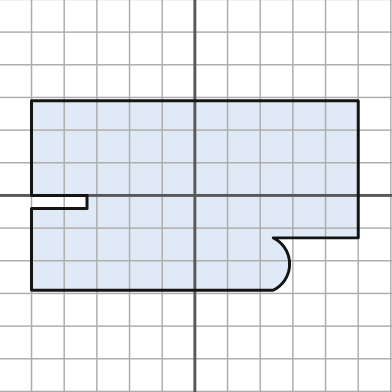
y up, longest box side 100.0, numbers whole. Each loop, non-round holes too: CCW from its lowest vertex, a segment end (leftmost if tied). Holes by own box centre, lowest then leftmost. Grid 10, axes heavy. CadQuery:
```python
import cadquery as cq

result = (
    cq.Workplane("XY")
    .moveTo(-50.0, -29.0)
    .lineTo(24.0, -29.0)
    .threePointArc((29.0, -21.0), (24.0, -13.0))
    .lineTo(50.0, -13.0)
    .lineTo(50.0, 29.0)
    .lineTo(-50.0, 29.0)
    .lineTo(-50.0, 0.0)
    .lineTo(-33.0, 0.0)
    .lineTo(-33.0, -4.0)
    .lineTo(-50.0, -4.0)
    .close()
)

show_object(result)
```